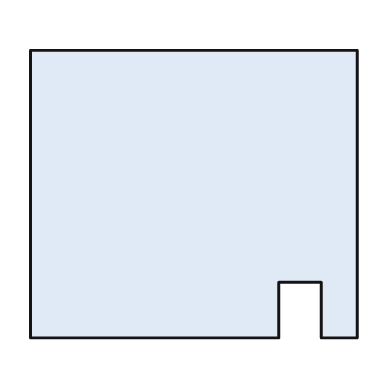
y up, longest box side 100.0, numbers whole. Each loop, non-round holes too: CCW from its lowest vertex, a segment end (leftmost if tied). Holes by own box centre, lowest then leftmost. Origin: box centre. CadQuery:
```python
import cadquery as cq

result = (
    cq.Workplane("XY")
    .moveTo(-50.0, -44.0)
    .lineTo(26.0, -44.0)
    .lineTo(26.0, -27.0)
    .lineTo(39.0, -27.0)
    .lineTo(39.0, -44.0)
    .lineTo(50.0, -44.0)
    .lineTo(50.0, 44.0)
    .lineTo(-50.0, 44.0)
    .close()
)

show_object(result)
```